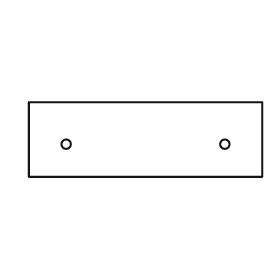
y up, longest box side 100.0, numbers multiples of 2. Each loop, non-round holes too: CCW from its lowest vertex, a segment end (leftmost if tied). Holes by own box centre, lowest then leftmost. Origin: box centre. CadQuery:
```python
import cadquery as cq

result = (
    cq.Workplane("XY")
    .moveTo(-50.0, -16.0)
    .lineTo(50.0, -16.0)
    .lineTo(50.0, 16.0)
    .lineTo(-50.0, 16.0)
    .close()
    .moveTo(-34.0, -2.0)
    .circle(2.0)
    .moveTo(34.0, -2.0)
    .circle(2.0)
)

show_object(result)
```